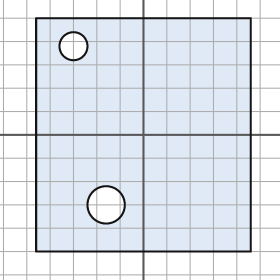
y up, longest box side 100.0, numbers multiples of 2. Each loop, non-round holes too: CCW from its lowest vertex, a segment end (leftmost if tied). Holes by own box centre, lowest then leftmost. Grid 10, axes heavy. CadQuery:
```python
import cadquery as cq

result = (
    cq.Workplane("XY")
    .moveTo(-46.0, -50.0)
    .lineTo(46.0, -50.0)
    .lineTo(46.0, 50.0)
    .lineTo(-46.0, 50.0)
    .close()
    .moveTo(-16.0, -30.0)
    .circle(8.0)
    .moveTo(-30.0, 38.0)
    .circle(6.0)
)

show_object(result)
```